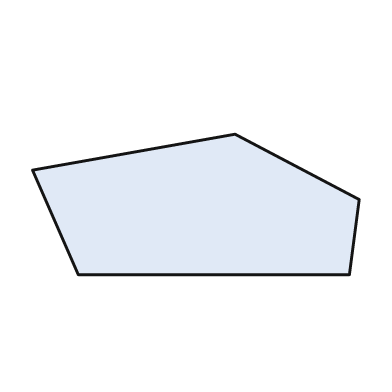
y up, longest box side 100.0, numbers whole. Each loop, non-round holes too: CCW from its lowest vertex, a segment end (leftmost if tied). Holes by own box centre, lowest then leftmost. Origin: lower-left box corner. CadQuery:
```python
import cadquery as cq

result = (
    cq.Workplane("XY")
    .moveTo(14.0, 0.0)
    .lineTo(97.0, 0.0)
    .lineTo(100.0, 23.0)
    .lineTo(62.0, 43.0)
    .lineTo(0.0, 32.0)
    .close()
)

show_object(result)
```